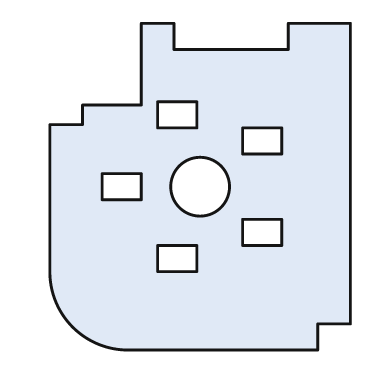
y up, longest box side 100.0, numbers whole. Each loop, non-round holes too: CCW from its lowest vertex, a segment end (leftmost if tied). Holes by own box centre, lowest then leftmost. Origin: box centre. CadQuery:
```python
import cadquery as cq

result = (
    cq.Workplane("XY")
    .moveTo(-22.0, -50.0)
    .lineTo(36.0, -50.0)
    .lineTo(36.0, -42.0)
    .lineTo(46.0, -42.0)
    .lineTo(46.0, 50.0)
    .lineTo(27.0, 50.0)
    .lineTo(27.0, 42.0)
    .lineTo(-8.0, 42.0)
    .lineTo(-8.0, 50.0)
    .lineTo(-18.0, 50.0)
    .lineTo(-18.0, 25.0)
    .lineTo(-36.0, 25.0)
    .lineTo(-36.0, 19.0)
    .lineTo(-46.0, 19.0)
    .lineTo(-46.0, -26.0)
    .threePointArc((-39.0, -43.0), (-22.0, -50.0))
    .close()
    .moveTo(-13.0, -26.0)
    .lineTo(-1.0, -26.0)
    .lineTo(-1.0, -18.0)
    .lineTo(-13.0, -18.0)
    .close()
    .moveTo(13.0, -18.0)
    .lineTo(25.0, -18.0)
    .lineTo(25.0, -10.0)
    .lineTo(13.0, -10.0)
    .close()
    .moveTo(-30.0, -4.0)
    .lineTo(-18.0, -4.0)
    .lineTo(-18.0, 4.0)
    .lineTo(-30.0, 4.0)
    .close()
    .moveTo(0.0, 0.0)
    .circle(9.0)
    .moveTo(13.0, 10.0)
    .lineTo(25.0, 10.0)
    .lineTo(25.0, 18.0)
    .lineTo(13.0, 18.0)
    .close()
    .moveTo(-13.0, 18.0)
    .lineTo(-1.0, 18.0)
    .lineTo(-1.0, 26.0)
    .lineTo(-13.0, 26.0)
    .close()
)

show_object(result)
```